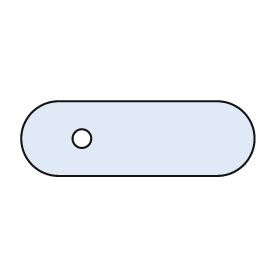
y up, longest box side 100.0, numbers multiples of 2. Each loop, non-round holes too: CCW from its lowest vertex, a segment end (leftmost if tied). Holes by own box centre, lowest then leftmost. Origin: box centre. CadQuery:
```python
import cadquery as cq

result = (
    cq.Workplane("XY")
    .moveTo(-34.0, -16.0)
    .lineTo(34.0, -16.0)
    .threePointArc((50.0, 0.0), (34.0, 16.0))
    .lineTo(-34.0, 16.0)
    .threePointArc((-50.0, 0.0), (-34.0, -16.0))
    .close()
    .moveTo(-24.0, 0.0)
    .circle(4.0)
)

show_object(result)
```